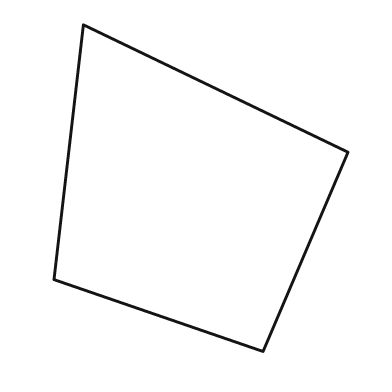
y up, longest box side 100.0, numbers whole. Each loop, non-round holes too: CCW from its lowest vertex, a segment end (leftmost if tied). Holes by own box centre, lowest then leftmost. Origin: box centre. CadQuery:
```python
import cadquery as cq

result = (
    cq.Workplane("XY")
    .moveTo(19.0, -50.0)
    .lineTo(45.0, 11.0)
    .lineTo(-36.0, 50.0)
    .lineTo(-45.0, -28.0)
    .close()
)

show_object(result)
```